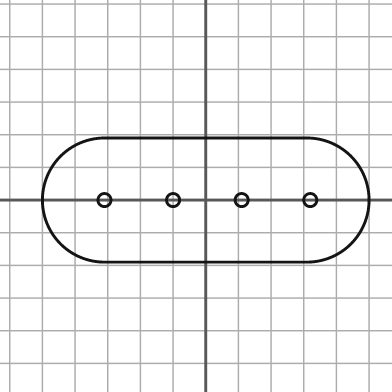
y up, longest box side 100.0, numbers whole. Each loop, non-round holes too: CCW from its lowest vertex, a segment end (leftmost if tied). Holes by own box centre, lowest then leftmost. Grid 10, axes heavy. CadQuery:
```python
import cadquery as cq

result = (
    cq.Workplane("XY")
    .moveTo(-31.0, -19.0)
    .lineTo(31.0, -19.0)
    .threePointArc((50.0, 0.0), (31.0, 19.0))
    .lineTo(-31.0, 19.0)
    .threePointArc((-50.0, 0.0), (-31.0, -19.0))
    .close()
    .moveTo(-31.0, 0.0)
    .circle(2.0)
    .moveTo(-10.0, 0.0)
    .circle(2.0)
    .moveTo(11.0, 0.0)
    .circle(2.0)
    .moveTo(32.0, 0.0)
    .circle(2.0)
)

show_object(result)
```